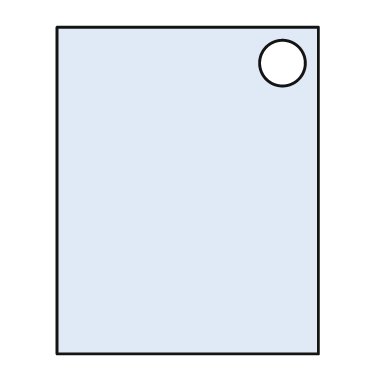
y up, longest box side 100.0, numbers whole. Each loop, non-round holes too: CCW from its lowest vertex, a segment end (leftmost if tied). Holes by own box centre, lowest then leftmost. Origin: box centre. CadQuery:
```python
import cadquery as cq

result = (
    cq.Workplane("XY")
    .moveTo(-40.0, -50.0)
    .lineTo(40.0, -50.0)
    .lineTo(40.0, 50.0)
    .lineTo(-40.0, 50.0)
    .close()
    .moveTo(29.0, 39.0)
    .circle(7.0)
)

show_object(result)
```